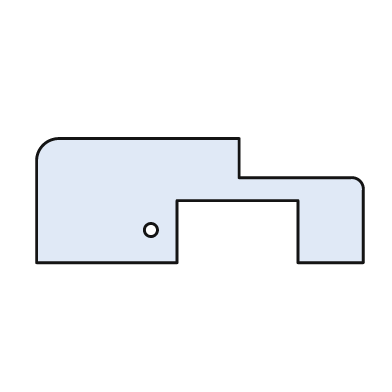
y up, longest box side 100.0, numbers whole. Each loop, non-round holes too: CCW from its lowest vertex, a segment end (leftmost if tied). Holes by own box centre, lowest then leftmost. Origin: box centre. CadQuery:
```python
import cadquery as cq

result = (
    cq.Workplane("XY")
    .moveTo(-50.0, -19.0)
    .lineTo(-7.0, -19.0)
    .lineTo(-7.0, 0.0)
    .lineTo(30.0, 0.0)
    .lineTo(30.0, -19.0)
    .lineTo(50.0, -19.0)
    .lineTo(50.0, 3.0)
    .threePointArc((49.0, 6.0), (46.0, 7.0))
    .lineTo(12.0, 7.0)
    .lineTo(12.0, 19.0)
    .lineTo(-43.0, 19.0)
    .threePointArc((-48.0, 17.0), (-50.0, 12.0))
    .close()
    .moveTo(-15.0, -9.0)
    .circle(2.0)
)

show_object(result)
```